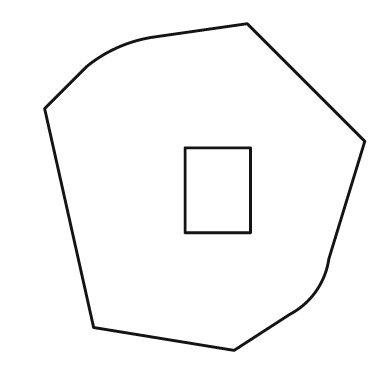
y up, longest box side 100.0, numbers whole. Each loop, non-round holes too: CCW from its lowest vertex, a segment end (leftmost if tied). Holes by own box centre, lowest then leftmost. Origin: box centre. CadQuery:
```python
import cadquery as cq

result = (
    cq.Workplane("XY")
    .moveTo(9.0, -50.0)
    .lineTo(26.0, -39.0)
    .threePointArc((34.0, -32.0), (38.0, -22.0))
    .lineTo(49.0, 14.0)
    .lineTo(13.0, 50.0)
    .lineTo(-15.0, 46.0)
    .threePointArc((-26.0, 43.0), (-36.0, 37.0))
    .lineTo(-49.0, 24.0)
    .lineTo(-34.0, -43.0)
    .close()
    .moveTo(-6.0, -14.0)
    .lineTo(14.0, -14.0)
    .lineTo(14.0, 12.0)
    .lineTo(-6.0, 12.0)
    .close()
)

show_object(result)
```